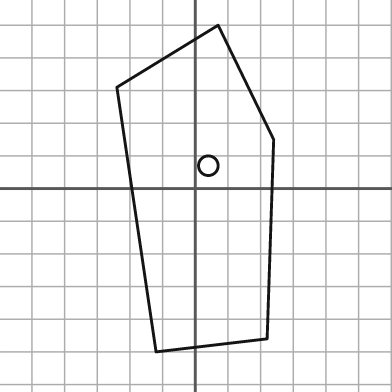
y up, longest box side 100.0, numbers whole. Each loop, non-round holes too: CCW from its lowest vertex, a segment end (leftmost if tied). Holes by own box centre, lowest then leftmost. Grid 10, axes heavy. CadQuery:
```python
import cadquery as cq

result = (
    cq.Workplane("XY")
    .moveTo(-12.0, -50.0)
    .lineTo(22.0, -46.0)
    .lineTo(24.0, 15.0)
    .lineTo(7.0, 50.0)
    .lineTo(-24.0, 31.0)
    .close()
    .moveTo(4.0, 7.0)
    .circle(3.0)
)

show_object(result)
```